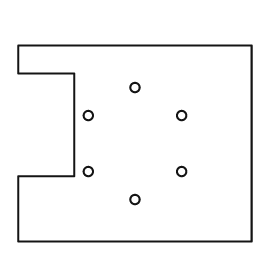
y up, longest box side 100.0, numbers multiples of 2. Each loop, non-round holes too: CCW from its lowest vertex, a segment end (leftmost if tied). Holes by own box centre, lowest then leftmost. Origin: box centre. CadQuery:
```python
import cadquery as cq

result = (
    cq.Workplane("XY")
    .moveTo(-50.0, -42.0)
    .lineTo(50.0, -42.0)
    .lineTo(50.0, 42.0)
    .lineTo(-50.0, 42.0)
    .lineTo(-50.0, 30.0)
    .lineTo(-26.0, 30.0)
    .lineTo(-26.0, -14.0)
    .lineTo(-50.0, -14.0)
    .close()
    .moveTo(0.0, -24.0)
    .circle(2.0)
    .moveTo(-20.0, -12.0)
    .circle(2.0)
    .moveTo(20.0, -12.0)
    .circle(2.0)
    .moveTo(-20.0, 12.0)
    .circle(2.0)
    .moveTo(20.0, 12.0)
    .circle(2.0)
    .moveTo(0.0, 24.0)
    .circle(2.0)
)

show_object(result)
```